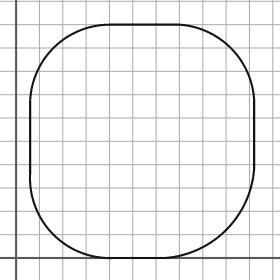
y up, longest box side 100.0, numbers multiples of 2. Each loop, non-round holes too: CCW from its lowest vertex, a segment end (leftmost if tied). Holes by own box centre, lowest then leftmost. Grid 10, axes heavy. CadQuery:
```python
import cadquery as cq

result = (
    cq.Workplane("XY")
    .moveTo(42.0, 0.0)
    .lineTo(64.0, 0.0)
    .threePointArc((90.0, 12.0), (102.0, 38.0))
    .lineTo(102.0, 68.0)
    .threePointArc((92.0, 90.0), (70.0, 100.0))
    .lineTo(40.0, 100.0)
    .threePointArc((16.0, 90.0), (6.0, 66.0))
    .lineTo(6.0, 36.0)
    .threePointArc((16.0, 10.0), (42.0, 0.0))
    .close()
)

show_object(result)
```